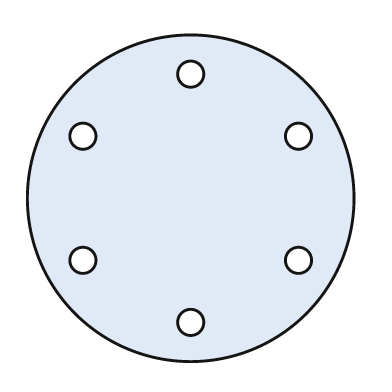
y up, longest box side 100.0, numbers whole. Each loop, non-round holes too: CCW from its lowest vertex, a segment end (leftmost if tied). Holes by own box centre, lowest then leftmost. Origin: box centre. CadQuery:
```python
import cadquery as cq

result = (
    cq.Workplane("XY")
    .moveTo(0.0, 0.0)
    .circle(50.0)
    .moveTo(0.0, -38.0)
    .circle(4.0)
    .moveTo(-33.0, -19.0)
    .circle(4.0)
    .moveTo(33.0, -19.0)
    .circle(4.0)
    .moveTo(-33.0, 19.0)
    .circle(4.0)
    .moveTo(33.0, 19.0)
    .circle(4.0)
    .moveTo(0.0, 38.0)
    .circle(4.0)
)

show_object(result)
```